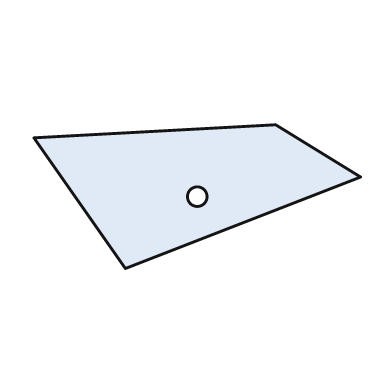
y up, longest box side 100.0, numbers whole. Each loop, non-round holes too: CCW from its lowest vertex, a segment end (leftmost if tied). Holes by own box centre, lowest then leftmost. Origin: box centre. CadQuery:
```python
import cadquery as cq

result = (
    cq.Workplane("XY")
    .moveTo(-22.0, -22.0)
    .lineTo(50.0, 6.0)
    .lineTo(24.0, 22.0)
    .lineTo(-50.0, 18.0)
    .close()
    .moveTo(0.0, 0.0)
    .circle(3.0)
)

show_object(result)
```